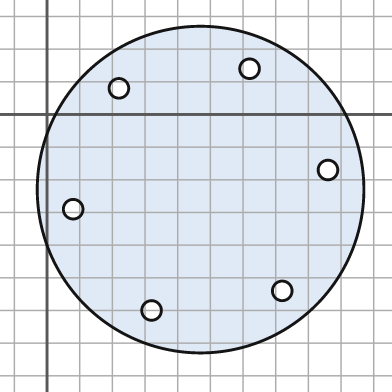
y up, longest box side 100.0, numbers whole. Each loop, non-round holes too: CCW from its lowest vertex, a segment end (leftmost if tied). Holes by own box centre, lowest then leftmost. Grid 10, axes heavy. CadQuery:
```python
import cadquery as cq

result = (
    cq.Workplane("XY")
    .moveTo(47.0, -23.0)
    .circle(50.0)
    .moveTo(32.0, -60.0)
    .circle(3.0)
    .moveTo(72.0, -54.0)
    .circle(3.0)
    .moveTo(8.0, -29.0)
    .circle(3.0)
    .moveTo(86.0, -17.0)
    .circle(3.0)
    .moveTo(22.0, 8.0)
    .circle(3.0)
    .moveTo(62.0, 14.0)
    .circle(3.0)
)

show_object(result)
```